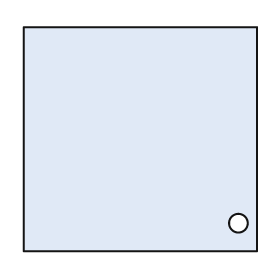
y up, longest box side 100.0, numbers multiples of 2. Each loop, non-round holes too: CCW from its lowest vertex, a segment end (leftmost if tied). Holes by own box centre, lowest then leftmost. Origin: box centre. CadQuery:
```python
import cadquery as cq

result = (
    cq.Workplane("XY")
    .moveTo(-50.0, -48.0)
    .lineTo(50.0, -48.0)
    .lineTo(50.0, 48.0)
    .lineTo(-50.0, 48.0)
    .close()
    .moveTo(42.0, -36.0)
    .circle(4.0)
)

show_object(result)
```